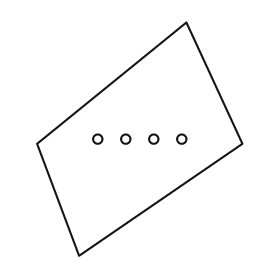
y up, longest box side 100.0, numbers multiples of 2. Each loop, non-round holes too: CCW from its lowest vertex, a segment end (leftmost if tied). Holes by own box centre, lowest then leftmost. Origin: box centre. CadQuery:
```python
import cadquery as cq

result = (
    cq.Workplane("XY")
    .moveTo(-26.0, -50.0)
    .lineTo(44.0, -2.0)
    .lineTo(20.0, 50.0)
    .lineTo(-44.0, -2.0)
    .close()
    .moveTo(-18.0, 0.0)
    .circle(2.0)
    .moveTo(-6.0, 0.0)
    .circle(2.0)
    .moveTo(6.0, 0.0)
    .circle(2.0)
    .moveTo(18.0, 0.0)
    .circle(2.0)
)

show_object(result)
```